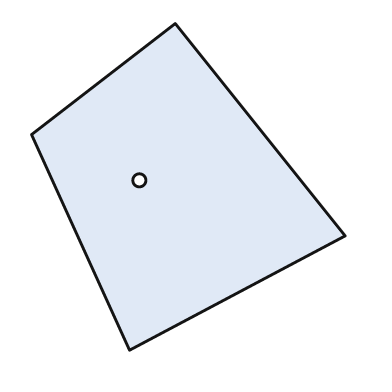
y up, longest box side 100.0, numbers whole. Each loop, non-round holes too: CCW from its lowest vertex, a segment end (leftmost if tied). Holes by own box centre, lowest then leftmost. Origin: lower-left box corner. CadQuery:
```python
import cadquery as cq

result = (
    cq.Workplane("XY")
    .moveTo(30.0, 0.0)
    .lineTo(96.0, 35.0)
    .lineTo(44.0, 100.0)
    .lineTo(0.0, 66.0)
    .close()
    .moveTo(33.0, 52.0)
    .circle(2.0)
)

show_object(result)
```